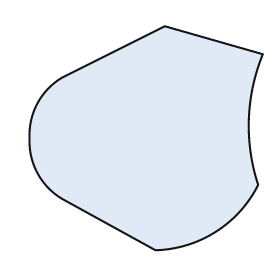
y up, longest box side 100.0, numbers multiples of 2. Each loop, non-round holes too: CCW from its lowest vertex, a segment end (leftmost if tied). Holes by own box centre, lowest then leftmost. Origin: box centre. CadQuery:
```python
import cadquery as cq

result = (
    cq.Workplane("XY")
    .moveTo(4.0, -48.0)
    .threePointArc((30.0, -40.0), (48.0, -20.0))
    .threePointArc((44.0, 8.0), (50.0, 36.0))
    .lineTo(8.0, 48.0)
    .lineTo(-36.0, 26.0)
    .threePointArc((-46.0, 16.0), (-50.0, 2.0))
    .lineTo(-50.0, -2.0)
    .threePointArc((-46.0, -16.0), (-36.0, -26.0))
    .close()
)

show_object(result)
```